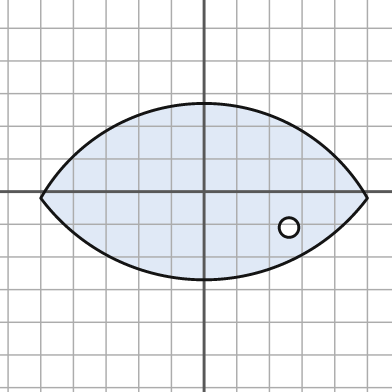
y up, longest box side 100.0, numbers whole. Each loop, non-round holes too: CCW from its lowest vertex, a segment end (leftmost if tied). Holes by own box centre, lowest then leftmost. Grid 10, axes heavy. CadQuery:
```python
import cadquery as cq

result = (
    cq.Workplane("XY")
    .moveTo(-50.0, -2.0)
    .threePointArc((0.0, -27.0), (50.0, -2.0))
    .threePointArc((0.0, 27.0), (-50.0, -2.0))
    .close()
    .moveTo(26.0, -11.0)
    .circle(3.0)
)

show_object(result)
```